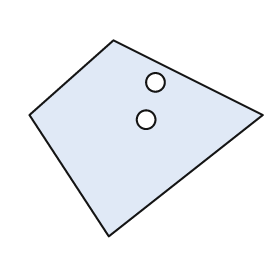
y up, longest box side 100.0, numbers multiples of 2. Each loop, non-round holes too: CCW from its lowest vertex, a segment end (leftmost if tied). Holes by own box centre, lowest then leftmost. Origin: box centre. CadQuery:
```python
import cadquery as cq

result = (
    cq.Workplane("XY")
    .moveTo(-16.0, -42.0)
    .lineTo(50.0, 10.0)
    .lineTo(-14.0, 42.0)
    .lineTo(-50.0, 10.0)
    .close()
    .moveTo(0.0, 8.0)
    .circle(4.0)
    .moveTo(4.0, 24.0)
    .circle(4.0)
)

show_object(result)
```